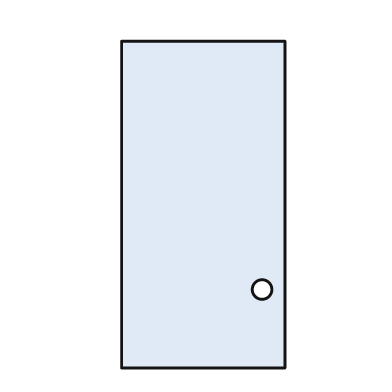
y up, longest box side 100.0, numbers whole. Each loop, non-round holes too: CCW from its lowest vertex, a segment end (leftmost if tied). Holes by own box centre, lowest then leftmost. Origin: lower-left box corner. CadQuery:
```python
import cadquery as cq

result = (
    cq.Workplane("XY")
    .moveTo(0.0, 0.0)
    .lineTo(50.0, 0.0)
    .lineTo(50.0, 100.0)
    .lineTo(0.0, 100.0)
    .close()
    .moveTo(43.0, 24.0)
    .circle(3.0)
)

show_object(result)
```